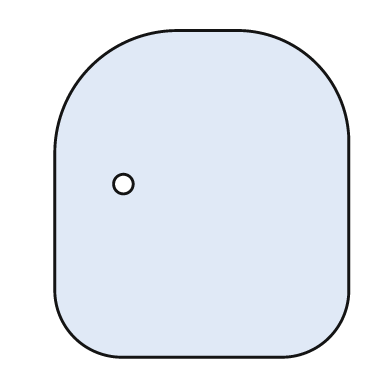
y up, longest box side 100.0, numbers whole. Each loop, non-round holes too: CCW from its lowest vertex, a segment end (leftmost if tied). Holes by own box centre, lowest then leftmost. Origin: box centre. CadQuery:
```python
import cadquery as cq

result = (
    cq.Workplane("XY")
    .moveTo(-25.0, -50.0)
    .lineTo(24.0, -50.0)
    .threePointArc((39.0, -44.0), (45.0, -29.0))
    .lineTo(45.0, 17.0)
    .threePointArc((35.0, 40.0), (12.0, 50.0))
    .lineTo(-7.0, 50.0)
    .threePointArc((-34.0, 39.0), (-45.0, 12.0))
    .lineTo(-45.0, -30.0)
    .threePointArc((-39.0, -44.0), (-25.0, -50.0))
    .close()
    .moveTo(-24.0, 3.0)
    .circle(3.0)
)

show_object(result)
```